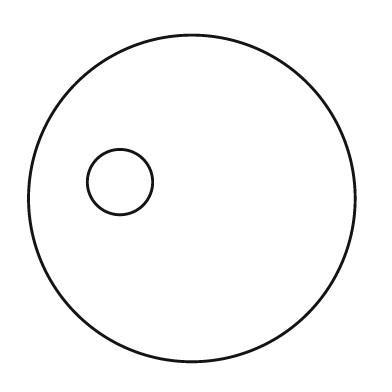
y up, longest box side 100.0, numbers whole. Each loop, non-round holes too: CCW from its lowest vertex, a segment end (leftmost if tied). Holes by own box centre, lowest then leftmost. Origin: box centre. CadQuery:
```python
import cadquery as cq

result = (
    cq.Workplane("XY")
    .moveTo(0.0, 0.0)
    .circle(50.0)
    .moveTo(-22.0, 5.0)
    .circle(10.0)
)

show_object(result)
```